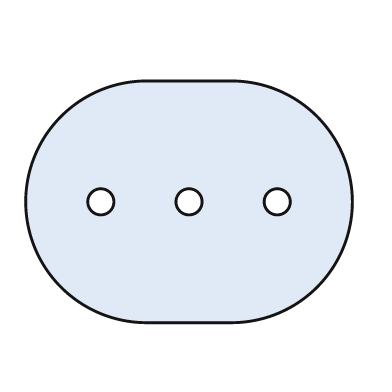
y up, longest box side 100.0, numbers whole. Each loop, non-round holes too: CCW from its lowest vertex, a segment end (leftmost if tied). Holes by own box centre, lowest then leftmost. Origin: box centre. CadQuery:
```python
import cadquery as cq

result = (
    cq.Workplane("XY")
    .moveTo(-13.0, -37.0)
    .lineTo(13.0, -37.0)
    .threePointArc((50.0, 0.0), (13.0, 37.0))
    .lineTo(-13.0, 37.0)
    .threePointArc((-50.0, 0.0), (-13.0, -37.0))
    .close()
    .moveTo(-27.0, 0.0)
    .circle(4.0)
    .moveTo(0.0, 0.0)
    .circle(4.0)
    .moveTo(27.0, 0.0)
    .circle(4.0)
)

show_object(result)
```